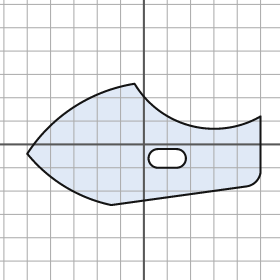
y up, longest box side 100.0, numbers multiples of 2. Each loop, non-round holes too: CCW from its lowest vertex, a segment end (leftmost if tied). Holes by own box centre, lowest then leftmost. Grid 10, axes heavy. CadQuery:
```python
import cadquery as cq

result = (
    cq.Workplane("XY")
    .moveTo(-14.0, -26.0)
    .lineTo(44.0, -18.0)
    .threePointArc((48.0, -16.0), (50.0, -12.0))
    .lineTo(50.0, 12.0)
    .threePointArc((20.0, 8.0), (-4.0, 26.0))
    .threePointArc((-30.0, 16.0), (-50.0, -4.0))
    .threePointArc((-34.0, -18.0), (-14.0, -26.0))
    .close()
    .moveTo(6.0, -10.0)
    .lineTo(14.0, -10.0)
    .threePointArc((18.0, -6.0), (14.0, -2.0))
    .lineTo(6.0, -2.0)
    .threePointArc((2.0, -6.0), (6.0, -10.0))
    .close()
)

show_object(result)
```